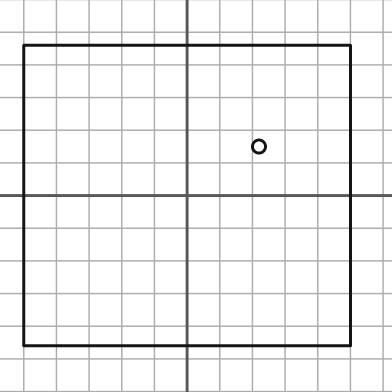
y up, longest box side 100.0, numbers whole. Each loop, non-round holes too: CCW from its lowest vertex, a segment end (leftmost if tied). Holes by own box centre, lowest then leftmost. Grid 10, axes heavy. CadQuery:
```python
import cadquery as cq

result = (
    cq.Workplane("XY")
    .moveTo(-50.0, -46.0)
    .lineTo(50.0, -46.0)
    .lineTo(50.0, 46.0)
    .lineTo(-50.0, 46.0)
    .close()
    .moveTo(22.0, 15.0)
    .circle(2.0)
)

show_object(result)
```